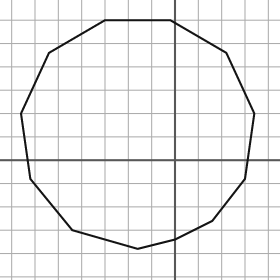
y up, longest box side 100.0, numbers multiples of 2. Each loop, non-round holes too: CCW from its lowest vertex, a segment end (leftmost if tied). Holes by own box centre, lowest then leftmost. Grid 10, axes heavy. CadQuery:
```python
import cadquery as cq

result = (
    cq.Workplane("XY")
    .moveTo(-16.0, -38.0)
    .lineTo(0.0, -34.0)
    .lineTo(16.0, -26.0)
    .lineTo(30.0, -8.0)
    .lineTo(34.0, 20.0)
    .lineTo(22.0, 46.0)
    .lineTo(-2.0, 60.0)
    .lineTo(-30.0, 60.0)
    .lineTo(-54.0, 46.0)
    .lineTo(-66.0, 20.0)
    .lineTo(-62.0, -8.0)
    .lineTo(-44.0, -30.0)
    .close()
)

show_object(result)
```